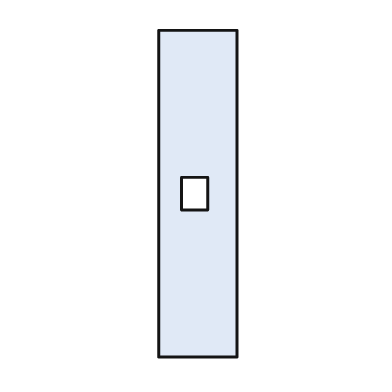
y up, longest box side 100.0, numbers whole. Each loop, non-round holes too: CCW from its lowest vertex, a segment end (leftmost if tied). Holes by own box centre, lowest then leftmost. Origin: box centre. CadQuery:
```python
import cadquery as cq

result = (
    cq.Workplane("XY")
    .moveTo(-12.0, -50.0)
    .lineTo(12.0, -50.0)
    .lineTo(12.0, 50.0)
    .lineTo(-12.0, 50.0)
    .close()
    .moveTo(-5.0, -5.0)
    .lineTo(3.0, -5.0)
    .lineTo(3.0, 5.0)
    .lineTo(-5.0, 5.0)
    .close()
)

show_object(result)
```